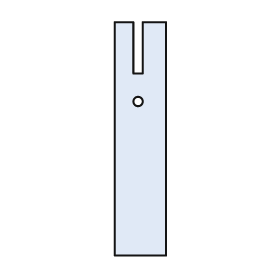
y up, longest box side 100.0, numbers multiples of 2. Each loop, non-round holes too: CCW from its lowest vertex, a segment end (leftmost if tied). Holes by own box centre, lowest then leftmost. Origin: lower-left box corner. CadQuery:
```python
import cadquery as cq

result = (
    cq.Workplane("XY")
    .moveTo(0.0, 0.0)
    .lineTo(22.0, 0.0)
    .lineTo(22.0, 100.0)
    .lineTo(12.0, 100.0)
    .lineTo(12.0, 78.0)
    .lineTo(8.0, 78.0)
    .lineTo(8.0, 100.0)
    .lineTo(0.0, 100.0)
    .close()
    .moveTo(10.0, 66.0)
    .circle(2.0)
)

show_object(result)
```